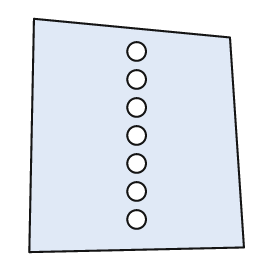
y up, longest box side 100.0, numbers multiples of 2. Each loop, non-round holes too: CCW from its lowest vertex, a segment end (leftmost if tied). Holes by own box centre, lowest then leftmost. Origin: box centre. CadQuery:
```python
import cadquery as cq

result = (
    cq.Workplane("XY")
    .moveTo(-46.0, -50.0)
    .lineTo(46.0, -48.0)
    .lineTo(40.0, 42.0)
    .lineTo(-44.0, 50.0)
    .close()
    .moveTo(0.0, -36.0)
    .circle(4.0)
    .moveTo(0.0, -24.0)
    .circle(4.0)
    .moveTo(0.0, -12.0)
    .circle(4.0)
    .moveTo(0.0, 0.0)
    .circle(4.0)
    .moveTo(0.0, 12.0)
    .circle(4.0)
    .moveTo(0.0, 24.0)
    .circle(4.0)
    .moveTo(0.0, 36.0)
    .circle(4.0)
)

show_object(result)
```